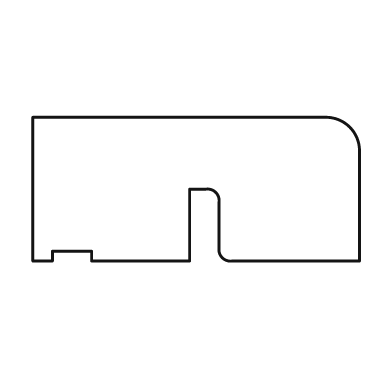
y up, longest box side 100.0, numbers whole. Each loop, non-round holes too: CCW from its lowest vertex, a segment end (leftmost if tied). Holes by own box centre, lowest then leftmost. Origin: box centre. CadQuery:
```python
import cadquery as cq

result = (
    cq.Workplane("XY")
    .moveTo(-50.0, -22.0)
    .lineTo(-44.0, -22.0)
    .lineTo(-44.0, -19.0)
    .lineTo(-32.0, -19.0)
    .lineTo(-32.0, -22.0)
    .lineTo(-2.0, -22.0)
    .lineTo(-2.0, 0.0)
    .lineTo(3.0, 0.0)
    .threePointArc((6.0, -1.0), (7.0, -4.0))
    .lineTo(7.0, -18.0)
    .threePointArc((8.0, -21.0), (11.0, -22.0))
    .lineTo(50.0, -22.0)
    .lineTo(50.0, 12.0)
    .threePointArc((47.0, 19.0), (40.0, 22.0))
    .lineTo(-50.0, 22.0)
    .close()
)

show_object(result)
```